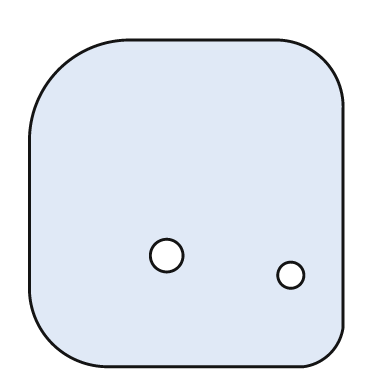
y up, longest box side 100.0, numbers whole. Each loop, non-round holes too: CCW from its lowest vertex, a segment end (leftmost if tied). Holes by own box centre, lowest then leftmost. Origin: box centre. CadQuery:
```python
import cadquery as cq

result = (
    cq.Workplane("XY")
    .moveTo(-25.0, -50.0)
    .lineTo(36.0, -50.0)
    .threePointArc((44.0, -46.0), (48.0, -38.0))
    .lineTo(48.0, 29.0)
    .threePointArc((42.0, 44.0), (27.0, 50.0))
    .lineTo(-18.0, 50.0)
    .threePointArc((-39.0, 41.0), (-48.0, 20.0))
    .lineTo(-48.0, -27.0)
    .threePointArc((-41.0, -43.0), (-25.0, -50.0))
    .close()
    .moveTo(32.0, -22.0)
    .circle(4.0)
    .moveTo(-6.0, -16.0)
    .circle(5.0)
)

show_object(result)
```